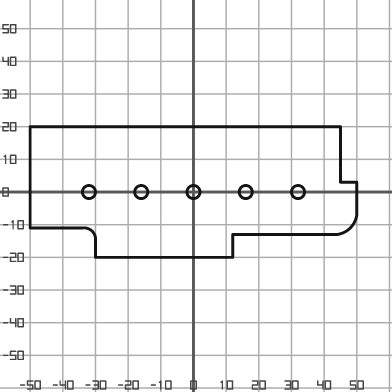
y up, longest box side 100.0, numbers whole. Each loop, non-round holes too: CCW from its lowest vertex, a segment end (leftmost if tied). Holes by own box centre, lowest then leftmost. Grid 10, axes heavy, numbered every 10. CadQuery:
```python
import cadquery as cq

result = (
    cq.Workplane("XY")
    .moveTo(-30.0, -20.0)
    .lineTo(12.0, -20.0)
    .lineTo(12.0, -13.0)
    .lineTo(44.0, -13.0)
    .threePointArc((48.0, -11.0), (50.0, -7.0))
    .lineTo(50.0, 3.0)
    .lineTo(45.0, 3.0)
    .lineTo(45.0, 20.0)
    .lineTo(-50.0, 20.0)
    .lineTo(-50.0, -11.0)
    .lineTo(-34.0, -11.0)
    .threePointArc((-31.0, -12.0), (-30.0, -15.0))
    .close()
    .moveTo(-32.0, 0.0)
    .circle(2.0)
    .moveTo(-16.0, 0.0)
    .circle(2.0)
    .moveTo(0.0, 0.0)
    .circle(2.0)
    .moveTo(16.0, 0.0)
    .circle(2.0)
    .moveTo(32.0, 0.0)
    .circle(2.0)
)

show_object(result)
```